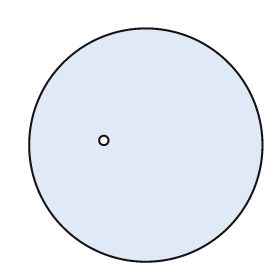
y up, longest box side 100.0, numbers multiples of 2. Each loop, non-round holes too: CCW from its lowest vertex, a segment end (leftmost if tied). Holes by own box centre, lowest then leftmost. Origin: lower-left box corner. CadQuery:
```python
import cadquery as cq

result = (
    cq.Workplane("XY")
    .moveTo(50.0, 50.0)
    .circle(50.0)
    .moveTo(32.0, 52.0)
    .circle(2.0)
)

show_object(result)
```